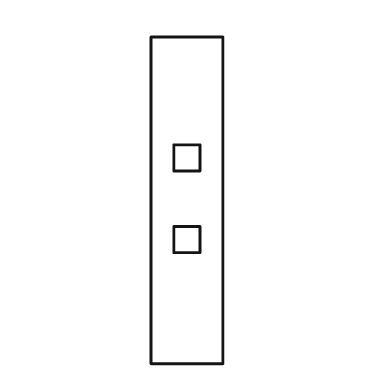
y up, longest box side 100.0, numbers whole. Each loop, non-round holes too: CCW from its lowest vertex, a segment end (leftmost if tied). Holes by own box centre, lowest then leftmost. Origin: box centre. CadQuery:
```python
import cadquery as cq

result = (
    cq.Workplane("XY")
    .moveTo(-11.0, -50.0)
    .lineTo(11.0, -50.0)
    .lineTo(11.0, 50.0)
    .lineTo(-11.0, 50.0)
    .close()
    .moveTo(-4.0, -16.0)
    .lineTo(4.0, -16.0)
    .lineTo(4.0, -8.0)
    .lineTo(-4.0, -8.0)
    .close()
    .moveTo(-4.0, 9.0)
    .lineTo(4.0, 9.0)
    .lineTo(4.0, 17.0)
    .lineTo(-4.0, 17.0)
    .close()
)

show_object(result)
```